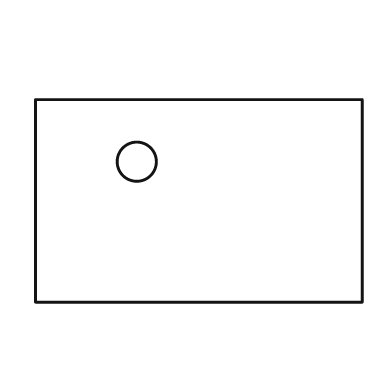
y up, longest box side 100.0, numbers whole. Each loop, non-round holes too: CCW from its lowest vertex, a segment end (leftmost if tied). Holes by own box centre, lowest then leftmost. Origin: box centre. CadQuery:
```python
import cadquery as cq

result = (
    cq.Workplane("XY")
    .moveTo(-50.0, -31.0)
    .lineTo(50.0, -31.0)
    .lineTo(50.0, 31.0)
    .lineTo(-50.0, 31.0)
    .close()
    .moveTo(-19.0, 12.0)
    .circle(6.0)
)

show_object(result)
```